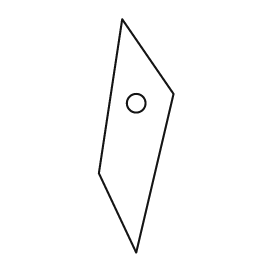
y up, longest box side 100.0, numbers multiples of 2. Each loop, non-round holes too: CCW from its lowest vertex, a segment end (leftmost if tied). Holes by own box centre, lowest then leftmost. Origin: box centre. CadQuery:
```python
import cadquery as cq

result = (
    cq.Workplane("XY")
    .moveTo(0.0, -50.0)
    .lineTo(16.0, 18.0)
    .lineTo(-6.0, 50.0)
    .lineTo(-16.0, -16.0)
    .close()
    .moveTo(0.0, 14.0)
    .circle(4.0)
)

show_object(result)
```